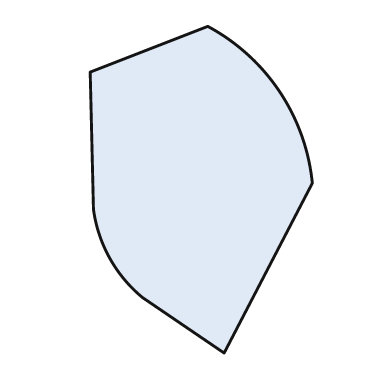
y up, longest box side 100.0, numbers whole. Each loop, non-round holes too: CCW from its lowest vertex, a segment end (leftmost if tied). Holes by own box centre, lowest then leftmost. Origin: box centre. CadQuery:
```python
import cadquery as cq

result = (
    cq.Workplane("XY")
    .moveTo(7.0, -50.0)
    .lineTo(34.0, 2.0)
    .threePointArc((24.0, 30.0), (2.0, 50.0))
    .lineTo(-34.0, 36.0)
    .lineTo(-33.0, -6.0)
    .threePointArc((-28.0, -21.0), (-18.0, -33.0))
    .close()
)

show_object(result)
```